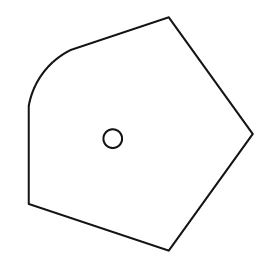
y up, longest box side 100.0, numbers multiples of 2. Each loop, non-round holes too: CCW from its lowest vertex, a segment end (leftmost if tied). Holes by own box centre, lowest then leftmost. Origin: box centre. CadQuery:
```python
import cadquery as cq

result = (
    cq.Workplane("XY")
    .moveTo(12.0, -50.0)
    .lineTo(48.0, 0.0)
    .lineTo(12.0, 50.0)
    .lineTo(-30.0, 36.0)
    .threePointArc((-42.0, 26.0), (-48.0, 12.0))
    .lineTo(-48.0, -30.0)
    .close()
    .moveTo(-12.0, -2.0)
    .circle(4.0)
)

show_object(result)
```